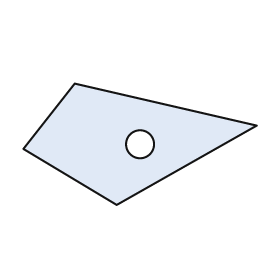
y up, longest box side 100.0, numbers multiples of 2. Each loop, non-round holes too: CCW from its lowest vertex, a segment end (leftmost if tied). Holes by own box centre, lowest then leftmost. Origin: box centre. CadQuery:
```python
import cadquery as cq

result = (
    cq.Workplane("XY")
    .moveTo(-10.0, -26.0)
    .lineTo(50.0, 8.0)
    .lineTo(-28.0, 26.0)
    .lineTo(-50.0, -2.0)
    .close()
    .moveTo(0.0, 0.0)
    .circle(6.0)
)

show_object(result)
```